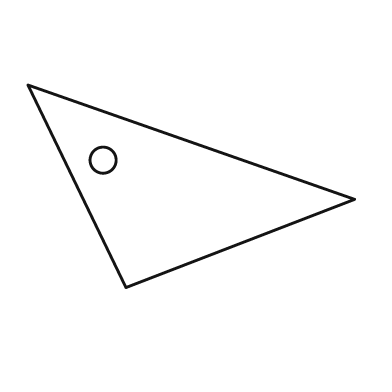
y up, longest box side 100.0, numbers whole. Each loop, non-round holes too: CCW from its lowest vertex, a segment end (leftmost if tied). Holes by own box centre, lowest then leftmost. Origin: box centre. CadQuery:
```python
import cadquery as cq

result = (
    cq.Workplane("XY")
    .moveTo(-20.0, -31.0)
    .lineTo(50.0, -4.0)
    .lineTo(-50.0, 31.0)
    .close()
    .moveTo(-27.0, 8.0)
    .circle(4.0)
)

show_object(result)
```